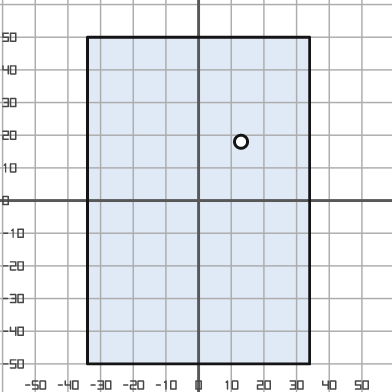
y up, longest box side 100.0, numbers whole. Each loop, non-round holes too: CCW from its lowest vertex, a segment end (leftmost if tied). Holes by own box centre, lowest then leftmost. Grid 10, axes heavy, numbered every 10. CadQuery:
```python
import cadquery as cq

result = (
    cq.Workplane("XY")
    .moveTo(-34.0, -50.0)
    .lineTo(34.0, -50.0)
    .lineTo(34.0, 50.0)
    .lineTo(-34.0, 50.0)
    .close()
    .moveTo(13.0, 18.0)
    .circle(2.0)
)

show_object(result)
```